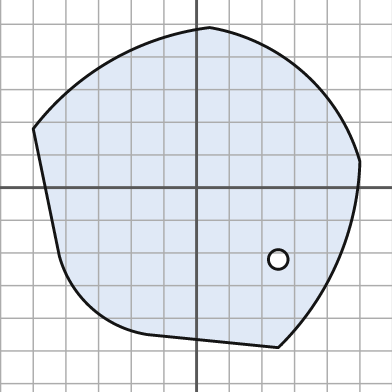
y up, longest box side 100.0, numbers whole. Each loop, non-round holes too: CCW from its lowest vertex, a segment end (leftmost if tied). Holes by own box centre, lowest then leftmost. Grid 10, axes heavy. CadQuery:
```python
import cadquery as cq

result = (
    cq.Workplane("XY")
    .moveTo(25.0, -49.0)
    .threePointArc((43.0, -23.0), (50.0, 8.0))
    .threePointArc((33.0, 35.0), (4.0, 49.0))
    .threePointArc((-26.0, 39.0), (-50.0, 18.0))
    .lineTo(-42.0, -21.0)
    .threePointArc((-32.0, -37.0), (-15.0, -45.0))
    .close()
    .moveTo(25.0, -22.0)
    .circle(3.0)
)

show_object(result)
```